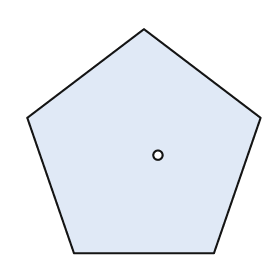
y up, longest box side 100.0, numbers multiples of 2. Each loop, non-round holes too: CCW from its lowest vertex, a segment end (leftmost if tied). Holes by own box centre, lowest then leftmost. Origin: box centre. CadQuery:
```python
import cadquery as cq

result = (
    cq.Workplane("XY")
    .moveTo(-30.0, -48.0)
    .lineTo(30.0, -48.0)
    .lineTo(50.0, 10.0)
    .lineTo(0.0, 48.0)
    .lineTo(-50.0, 10.0)
    .close()
    .moveTo(6.0, -6.0)
    .circle(2.0)
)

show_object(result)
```